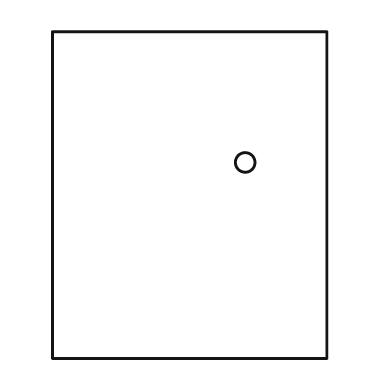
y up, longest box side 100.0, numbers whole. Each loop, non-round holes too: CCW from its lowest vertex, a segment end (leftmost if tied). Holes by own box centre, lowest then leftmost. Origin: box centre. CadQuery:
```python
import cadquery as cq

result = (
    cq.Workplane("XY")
    .moveTo(-42.0, -50.0)
    .lineTo(42.0, -50.0)
    .lineTo(42.0, 50.0)
    .lineTo(-42.0, 50.0)
    .close()
    .moveTo(17.0, 10.0)
    .circle(3.0)
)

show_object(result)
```